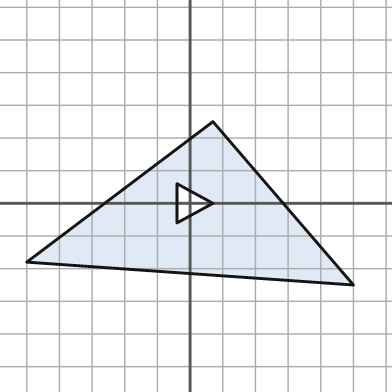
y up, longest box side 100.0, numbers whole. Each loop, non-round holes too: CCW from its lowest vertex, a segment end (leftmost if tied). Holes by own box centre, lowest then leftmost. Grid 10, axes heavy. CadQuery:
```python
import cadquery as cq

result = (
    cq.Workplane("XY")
    .moveTo(50.0, -25.0)
    .lineTo(7.0, 25.0)
    .lineTo(-50.0, -18.0)
    .close()
    .moveTo(-4.0, -6.0)
    .lineTo(7.0, 0.0)
    .lineTo(-4.0, 6.0)
    .close()
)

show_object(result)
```